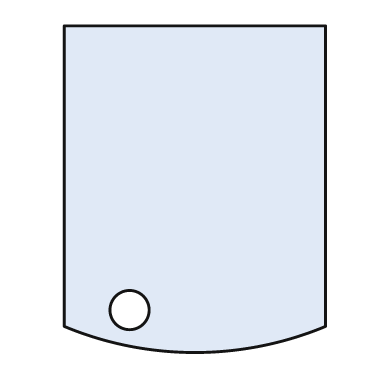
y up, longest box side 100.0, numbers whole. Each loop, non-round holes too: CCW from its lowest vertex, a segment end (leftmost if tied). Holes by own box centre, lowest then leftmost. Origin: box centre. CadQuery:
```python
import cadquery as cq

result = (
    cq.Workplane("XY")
    .moveTo(-40.0, -42.0)
    .threePointArc((0.0, -50.0), (40.0, -42.0))
    .lineTo(40.0, 50.0)
    .lineTo(-40.0, 50.0)
    .close()
    .moveTo(-20.0, -37.0)
    .circle(6.0)
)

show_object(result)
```